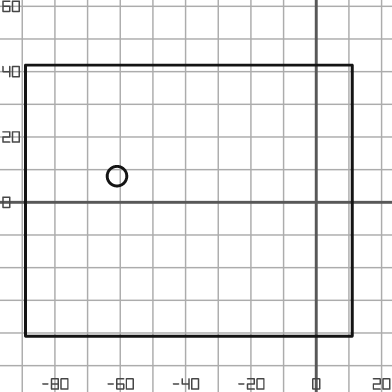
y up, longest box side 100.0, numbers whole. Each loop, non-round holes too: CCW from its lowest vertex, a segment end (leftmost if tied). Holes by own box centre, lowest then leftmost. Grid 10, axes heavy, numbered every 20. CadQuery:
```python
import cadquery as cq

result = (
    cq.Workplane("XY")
    .moveTo(-89.0, -41.0)
    .lineTo(11.0, -41.0)
    .lineTo(11.0, 42.0)
    .lineTo(-89.0, 42.0)
    .close()
    .moveTo(-61.0, 8.0)
    .circle(3.0)
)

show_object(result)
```